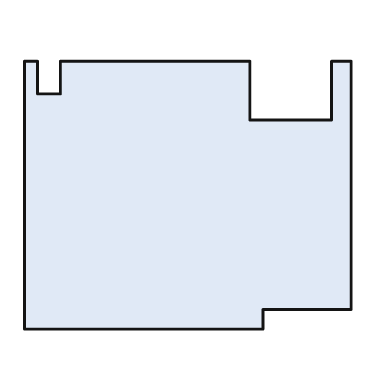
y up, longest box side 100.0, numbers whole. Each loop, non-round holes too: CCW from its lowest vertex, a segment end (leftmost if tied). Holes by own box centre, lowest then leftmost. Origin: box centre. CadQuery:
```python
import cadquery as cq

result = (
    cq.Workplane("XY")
    .moveTo(-50.0, -41.0)
    .lineTo(23.0, -41.0)
    .lineTo(23.0, -35.0)
    .lineTo(50.0, -35.0)
    .lineTo(50.0, 41.0)
    .lineTo(44.0, 41.0)
    .lineTo(44.0, 23.0)
    .lineTo(19.0, 23.0)
    .lineTo(19.0, 41.0)
    .lineTo(-39.0, 41.0)
    .lineTo(-39.0, 31.0)
    .lineTo(-46.0, 31.0)
    .lineTo(-46.0, 41.0)
    .lineTo(-50.0, 41.0)
    .close()
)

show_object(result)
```